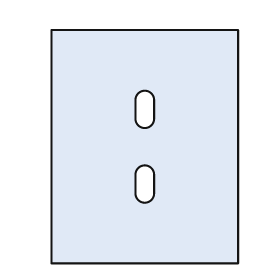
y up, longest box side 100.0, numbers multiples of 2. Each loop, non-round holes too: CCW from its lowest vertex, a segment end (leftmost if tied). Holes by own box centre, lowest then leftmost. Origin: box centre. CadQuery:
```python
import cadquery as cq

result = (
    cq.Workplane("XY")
    .moveTo(-40.0, -50.0)
    .lineTo(40.0, -50.0)
    .lineTo(40.0, 50.0)
    .lineTo(-40.0, 50.0)
    .close()
    .moveTo(-4.0, -20.0)
    .threePointArc((0.0, -24.0), (4.0, -20.0))
    .lineTo(4.0, -12.0)
    .threePointArc((0.0, -8.0), (-4.0, -12.0))
    .close()
    .moveTo(-4.0, 12.0)
    .threePointArc((0.0, 8.0), (4.0, 12.0))
    .lineTo(4.0, 20.0)
    .threePointArc((0.0, 24.0), (-4.0, 20.0))
    .close()
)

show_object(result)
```